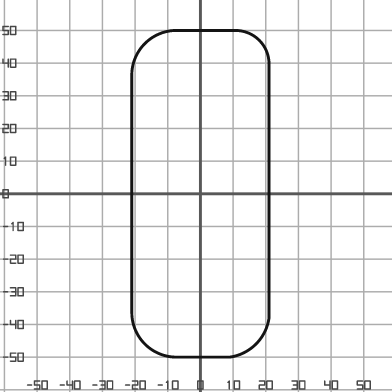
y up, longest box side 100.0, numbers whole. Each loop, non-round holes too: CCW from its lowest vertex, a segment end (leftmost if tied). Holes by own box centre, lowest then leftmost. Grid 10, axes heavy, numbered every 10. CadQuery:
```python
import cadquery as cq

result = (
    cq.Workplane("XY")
    .moveTo(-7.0, -50.0)
    .lineTo(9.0, -50.0)
    .threePointArc((17.0, -46.0), (21.0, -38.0))
    .lineTo(21.0, 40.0)
    .threePointArc((18.0, 47.0), (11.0, 50.0))
    .lineTo(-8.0, 50.0)
    .threePointArc((-17.0, 46.0), (-21.0, 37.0))
    .lineTo(-21.0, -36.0)
    .threePointArc((-17.0, -46.0), (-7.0, -50.0))
    .close()
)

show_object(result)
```